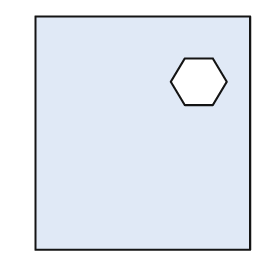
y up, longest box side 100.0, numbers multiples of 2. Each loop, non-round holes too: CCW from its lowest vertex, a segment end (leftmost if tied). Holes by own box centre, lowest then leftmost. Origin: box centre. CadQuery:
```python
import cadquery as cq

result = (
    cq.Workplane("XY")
    .moveTo(-46.0, -50.0)
    .lineTo(46.0, -50.0)
    .lineTo(46.0, 50.0)
    .lineTo(-46.0, 50.0)
    .close()
    .moveTo(18.0, 12.0)
    .lineTo(30.0, 12.0)
    .lineTo(36.0, 22.0)
    .lineTo(30.0, 32.0)
    .lineTo(18.0, 32.0)
    .lineTo(12.0, 22.0)
    .close()
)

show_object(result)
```